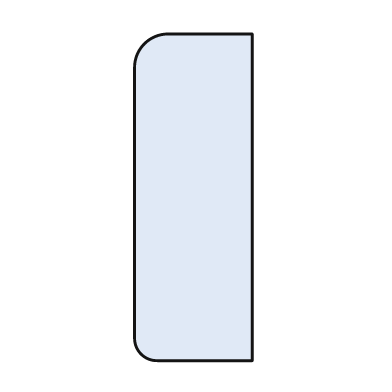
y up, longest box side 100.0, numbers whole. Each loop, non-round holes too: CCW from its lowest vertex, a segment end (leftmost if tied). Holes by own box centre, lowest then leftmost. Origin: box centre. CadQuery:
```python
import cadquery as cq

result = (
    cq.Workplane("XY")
    .moveTo(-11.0, -50.0)
    .lineTo(18.0, -50.0)
    .lineTo(18.0, 50.0)
    .lineTo(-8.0, 50.0)
    .threePointArc((-15.0, 47.0), (-18.0, 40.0))
    .lineTo(-18.0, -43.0)
    .threePointArc((-16.0, -48.0), (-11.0, -50.0))
    .close()
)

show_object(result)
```